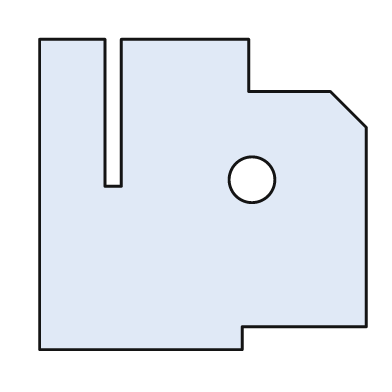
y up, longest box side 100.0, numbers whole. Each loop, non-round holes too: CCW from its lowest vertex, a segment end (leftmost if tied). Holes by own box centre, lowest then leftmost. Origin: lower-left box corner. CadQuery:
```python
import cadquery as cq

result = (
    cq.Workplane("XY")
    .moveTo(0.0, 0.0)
    .lineTo(62.0, 0.0)
    .lineTo(62.0, 7.0)
    .lineTo(100.0, 7.0)
    .lineTo(100.0, 68.0)
    .lineTo(89.0, 79.0)
    .lineTo(64.0, 79.0)
    .lineTo(64.0, 95.0)
    .lineTo(25.0, 95.0)
    .lineTo(25.0, 50.0)
    .lineTo(20.0, 50.0)
    .lineTo(20.0, 95.0)
    .lineTo(0.0, 95.0)
    .close()
    .moveTo(65.0, 52.0)
    .circle(7.0)
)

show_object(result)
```